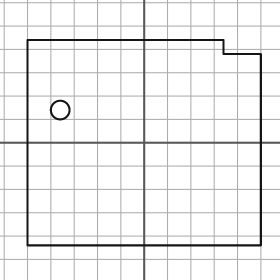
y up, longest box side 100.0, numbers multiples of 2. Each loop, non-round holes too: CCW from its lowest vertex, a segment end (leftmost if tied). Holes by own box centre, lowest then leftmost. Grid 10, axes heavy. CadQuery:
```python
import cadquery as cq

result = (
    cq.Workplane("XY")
    .moveTo(-50.0, -44.0)
    .lineTo(50.0, -44.0)
    .lineTo(50.0, 38.0)
    .lineTo(34.0, 38.0)
    .lineTo(34.0, 44.0)
    .lineTo(-50.0, 44.0)
    .close()
    .moveTo(-36.0, 14.0)
    .circle(4.0)
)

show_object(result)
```